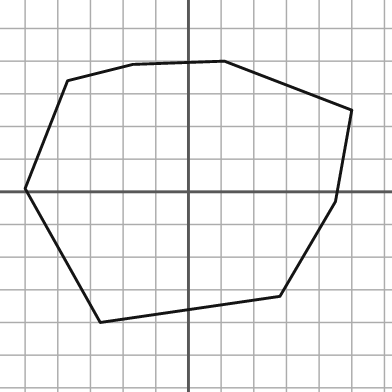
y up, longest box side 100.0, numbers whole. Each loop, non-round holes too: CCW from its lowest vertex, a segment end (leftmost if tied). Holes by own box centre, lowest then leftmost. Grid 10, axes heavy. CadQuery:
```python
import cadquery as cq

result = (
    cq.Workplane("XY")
    .moveTo(-27.0, -40.0)
    .lineTo(28.0, -32.0)
    .lineTo(45.0, -3.0)
    .lineTo(50.0, 25.0)
    .lineTo(11.0, 40.0)
    .lineTo(-17.0, 39.0)
    .lineTo(-37.0, 34.0)
    .lineTo(-50.0, 1.0)
    .close()
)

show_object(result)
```